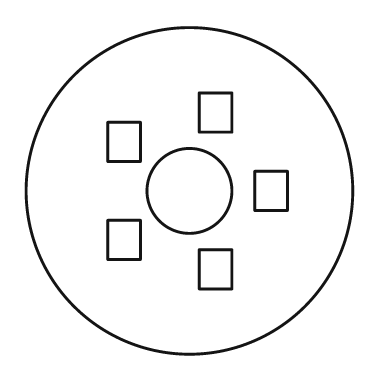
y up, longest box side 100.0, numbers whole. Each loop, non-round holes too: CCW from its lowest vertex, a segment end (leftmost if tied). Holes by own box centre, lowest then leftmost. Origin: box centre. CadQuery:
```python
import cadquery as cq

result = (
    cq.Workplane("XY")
    .moveTo(0.0, 0.0)
    .circle(50.0)
    .moveTo(3.0, -30.0)
    .lineTo(13.0, -30.0)
    .lineTo(13.0, -18.0)
    .lineTo(3.0, -18.0)
    .close()
    .moveTo(-25.0, -21.0)
    .lineTo(-15.0, -21.0)
    .lineTo(-15.0, -9.0)
    .lineTo(-25.0, -9.0)
    .close()
    .moveTo(0.0, 0.0)
    .circle(13.0)
    .moveTo(20.0, -6.0)
    .lineTo(30.0, -6.0)
    .lineTo(30.0, 6.0)
    .lineTo(20.0, 6.0)
    .close()
    .moveTo(-25.0, 9.0)
    .lineTo(-15.0, 9.0)
    .lineTo(-15.0, 21.0)
    .lineTo(-25.0, 21.0)
    .close()
    .moveTo(3.0, 18.0)
    .lineTo(13.0, 18.0)
    .lineTo(13.0, 30.0)
    .lineTo(3.0, 30.0)
    .close()
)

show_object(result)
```